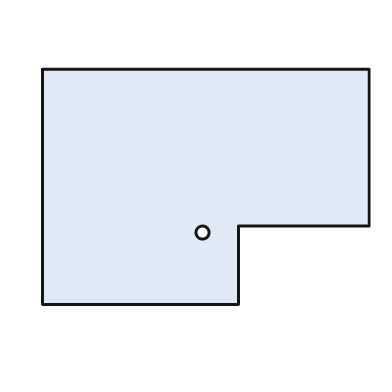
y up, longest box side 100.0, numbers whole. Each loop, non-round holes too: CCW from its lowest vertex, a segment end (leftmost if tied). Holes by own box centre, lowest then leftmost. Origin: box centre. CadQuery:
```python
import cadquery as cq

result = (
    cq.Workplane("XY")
    .moveTo(-50.0, -36.0)
    .lineTo(10.0, -36.0)
    .lineTo(10.0, -12.0)
    .lineTo(50.0, -12.0)
    .lineTo(50.0, 36.0)
    .lineTo(-50.0, 36.0)
    .close()
    .moveTo(-1.0, -14.0)
    .circle(2.0)
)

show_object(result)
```